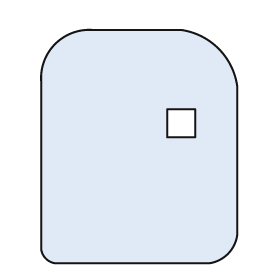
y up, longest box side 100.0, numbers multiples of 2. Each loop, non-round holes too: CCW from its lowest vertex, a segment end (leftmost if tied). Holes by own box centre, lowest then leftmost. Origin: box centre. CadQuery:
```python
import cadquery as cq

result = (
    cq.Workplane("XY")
    .moveTo(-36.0, -50.0)
    .lineTo(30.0, -50.0)
    .threePointArc((38.0, -46.0), (42.0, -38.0))
    .lineTo(42.0, 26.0)
    .threePointArc((34.0, 42.0), (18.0, 50.0))
    .lineTo(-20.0, 50.0)
    .threePointArc((-36.0, 44.0), (-42.0, 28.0))
    .lineTo(-42.0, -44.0)
    .threePointArc((-40.0, -48.0), (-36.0, -50.0))
    .close()
    .moveTo(12.0, 4.0)
    .lineTo(24.0, 4.0)
    .lineTo(24.0, 16.0)
    .lineTo(12.0, 16.0)
    .close()
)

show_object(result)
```